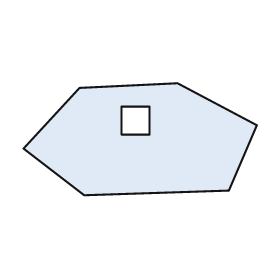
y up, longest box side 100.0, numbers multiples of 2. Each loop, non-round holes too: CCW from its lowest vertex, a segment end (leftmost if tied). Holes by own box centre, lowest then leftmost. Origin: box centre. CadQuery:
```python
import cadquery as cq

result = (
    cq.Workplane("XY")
    .moveTo(-24.0, -24.0)
    .lineTo(38.0, -22.0)
    .lineTo(50.0, 6.0)
    .lineTo(16.0, 24.0)
    .lineTo(-26.0, 22.0)
    .lineTo(-50.0, -4.0)
    .close()
    .moveTo(-8.0, 2.0)
    .lineTo(4.0, 2.0)
    .lineTo(4.0, 14.0)
    .lineTo(-8.0, 14.0)
    .close()
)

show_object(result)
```